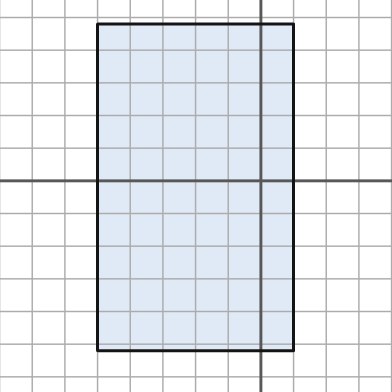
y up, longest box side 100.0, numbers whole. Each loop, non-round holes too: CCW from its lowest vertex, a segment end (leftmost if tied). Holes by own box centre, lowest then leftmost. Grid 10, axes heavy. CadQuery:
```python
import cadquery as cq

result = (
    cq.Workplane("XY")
    .moveTo(-50.0, -52.0)
    .lineTo(10.0, -52.0)
    .lineTo(10.0, 48.0)
    .lineTo(-50.0, 48.0)
    .close()
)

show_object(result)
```